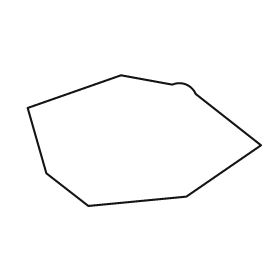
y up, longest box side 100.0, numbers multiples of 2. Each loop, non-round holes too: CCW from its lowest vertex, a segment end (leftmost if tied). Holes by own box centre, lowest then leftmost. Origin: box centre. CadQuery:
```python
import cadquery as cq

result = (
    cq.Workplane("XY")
    .moveTo(-24.0, -28.0)
    .lineTo(18.0, -24.0)
    .lineTo(50.0, -2.0)
    .lineTo(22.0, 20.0)
    .threePointArc((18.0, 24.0), (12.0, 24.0))
    .lineTo(-10.0, 28.0)
    .lineTo(-50.0, 14.0)
    .lineTo(-42.0, -14.0)
    .close()
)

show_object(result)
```